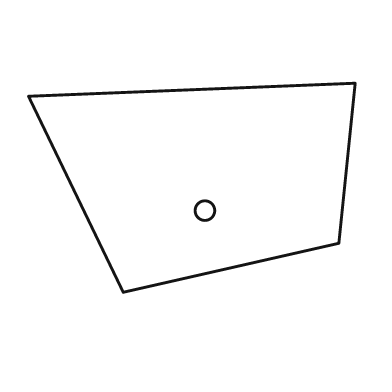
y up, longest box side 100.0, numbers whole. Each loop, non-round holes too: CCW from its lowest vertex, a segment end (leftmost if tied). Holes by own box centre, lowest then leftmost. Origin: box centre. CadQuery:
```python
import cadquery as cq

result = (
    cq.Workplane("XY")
    .moveTo(-21.0, -32.0)
    .lineTo(45.0, -17.0)
    .lineTo(50.0, 32.0)
    .lineTo(-50.0, 28.0)
    .close()
    .moveTo(4.0, -7.0)
    .circle(3.0)
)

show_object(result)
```